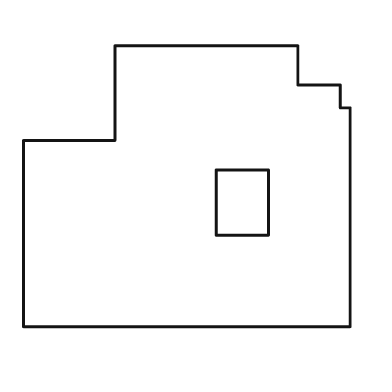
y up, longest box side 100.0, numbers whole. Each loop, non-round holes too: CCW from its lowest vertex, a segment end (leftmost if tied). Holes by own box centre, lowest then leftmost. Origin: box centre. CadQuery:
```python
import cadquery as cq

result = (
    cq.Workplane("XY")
    .moveTo(-50.0, -43.0)
    .lineTo(50.0, -43.0)
    .lineTo(50.0, 24.0)
    .lineTo(47.0, 24.0)
    .lineTo(47.0, 31.0)
    .lineTo(34.0, 31.0)
    .lineTo(34.0, 43.0)
    .lineTo(-22.0, 43.0)
    .lineTo(-22.0, 14.0)
    .lineTo(-50.0, 14.0)
    .close()
    .moveTo(9.0, -15.0)
    .lineTo(25.0, -15.0)
    .lineTo(25.0, 5.0)
    .lineTo(9.0, 5.0)
    .close()
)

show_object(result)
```